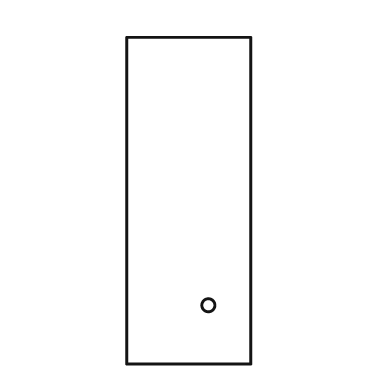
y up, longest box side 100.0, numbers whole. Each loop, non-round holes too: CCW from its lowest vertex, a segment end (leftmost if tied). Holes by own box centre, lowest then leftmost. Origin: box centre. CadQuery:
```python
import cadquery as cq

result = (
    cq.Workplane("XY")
    .moveTo(-19.0, -50.0)
    .lineTo(19.0, -50.0)
    .lineTo(19.0, 50.0)
    .lineTo(-19.0, 50.0)
    .close()
    .moveTo(6.0, -32.0)
    .circle(2.0)
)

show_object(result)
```